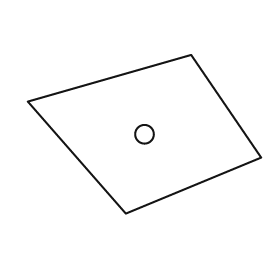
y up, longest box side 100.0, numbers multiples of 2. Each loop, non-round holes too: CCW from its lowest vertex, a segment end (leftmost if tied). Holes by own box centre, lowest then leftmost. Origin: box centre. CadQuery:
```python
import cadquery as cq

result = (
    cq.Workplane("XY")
    .moveTo(-8.0, -34.0)
    .lineTo(50.0, -10.0)
    .lineTo(20.0, 34.0)
    .lineTo(-50.0, 14.0)
    .close()
    .moveTo(0.0, 0.0)
    .circle(4.0)
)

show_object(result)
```